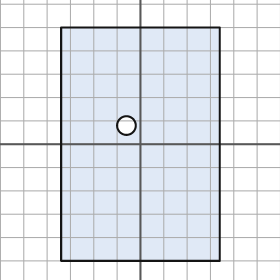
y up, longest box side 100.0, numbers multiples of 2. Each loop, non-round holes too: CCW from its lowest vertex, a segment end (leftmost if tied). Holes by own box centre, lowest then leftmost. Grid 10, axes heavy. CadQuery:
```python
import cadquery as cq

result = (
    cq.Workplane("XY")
    .moveTo(-34.0, -50.0)
    .lineTo(34.0, -50.0)
    .lineTo(34.0, 50.0)
    .lineTo(-34.0, 50.0)
    .close()
    .moveTo(-6.0, 8.0)
    .circle(4.0)
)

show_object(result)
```